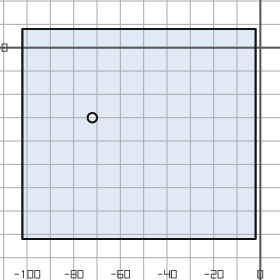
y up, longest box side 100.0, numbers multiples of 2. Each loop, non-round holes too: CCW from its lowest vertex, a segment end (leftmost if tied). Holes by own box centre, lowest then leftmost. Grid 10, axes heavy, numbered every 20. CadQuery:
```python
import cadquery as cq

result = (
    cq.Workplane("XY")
    .moveTo(-102.0, -82.0)
    .lineTo(-2.0, -82.0)
    .lineTo(-2.0, 8.0)
    .lineTo(-102.0, 8.0)
    .close()
    .moveTo(-72.0, -30.0)
    .circle(2.0)
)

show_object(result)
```